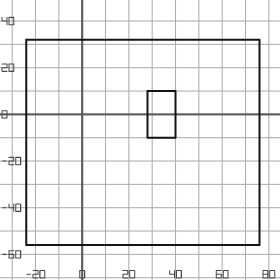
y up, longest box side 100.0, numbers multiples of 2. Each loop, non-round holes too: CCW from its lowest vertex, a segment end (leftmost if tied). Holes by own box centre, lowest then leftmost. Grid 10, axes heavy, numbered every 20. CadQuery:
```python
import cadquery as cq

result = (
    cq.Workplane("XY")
    .moveTo(-24.0, -56.0)
    .lineTo(76.0, -56.0)
    .lineTo(76.0, 32.0)
    .lineTo(-24.0, 32.0)
    .close()
    .moveTo(28.0, -10.0)
    .lineTo(40.0, -10.0)
    .lineTo(40.0, 10.0)
    .lineTo(28.0, 10.0)
    .close()
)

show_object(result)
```